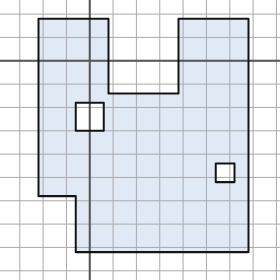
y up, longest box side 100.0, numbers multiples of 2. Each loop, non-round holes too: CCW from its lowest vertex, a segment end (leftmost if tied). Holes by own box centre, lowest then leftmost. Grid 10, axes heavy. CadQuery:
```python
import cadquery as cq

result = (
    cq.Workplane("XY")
    .moveTo(-6.0, -82.0)
    .lineTo(68.0, -82.0)
    .lineTo(68.0, 18.0)
    .lineTo(38.0, 18.0)
    .lineTo(38.0, -14.0)
    .lineTo(8.0, -14.0)
    .lineTo(8.0, 18.0)
    .lineTo(-22.0, 18.0)
    .lineTo(-22.0, -58.0)
    .lineTo(-6.0, -58.0)
    .close()
    .moveTo(54.0, -52.0)
    .lineTo(62.0, -52.0)
    .lineTo(62.0, -44.0)
    .lineTo(54.0, -44.0)
    .close()
    .moveTo(-6.0, -30.0)
    .lineTo(6.0, -30.0)
    .lineTo(6.0, -18.0)
    .lineTo(-6.0, -18.0)
    .close()
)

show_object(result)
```